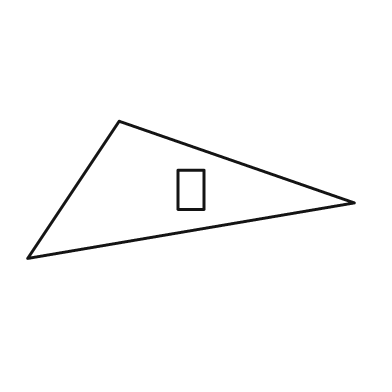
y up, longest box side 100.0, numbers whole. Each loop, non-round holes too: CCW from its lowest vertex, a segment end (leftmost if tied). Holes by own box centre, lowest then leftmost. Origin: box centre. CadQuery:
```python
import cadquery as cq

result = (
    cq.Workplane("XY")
    .moveTo(-50.0, -21.0)
    .lineTo(50.0, -4.0)
    .lineTo(-22.0, 21.0)
    .close()
    .moveTo(-4.0, -6.0)
    .lineTo(4.0, -6.0)
    .lineTo(4.0, 6.0)
    .lineTo(-4.0, 6.0)
    .close()
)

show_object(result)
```